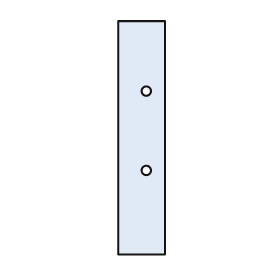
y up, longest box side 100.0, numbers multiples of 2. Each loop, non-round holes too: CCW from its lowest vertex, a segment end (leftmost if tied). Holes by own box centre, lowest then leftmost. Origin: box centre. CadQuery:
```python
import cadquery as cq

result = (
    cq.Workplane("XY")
    .moveTo(-10.0, -50.0)
    .lineTo(10.0, -50.0)
    .lineTo(10.0, 50.0)
    .lineTo(-10.0, 50.0)
    .close()
    .moveTo(2.0, -14.0)
    .circle(2.0)
    .moveTo(2.0, 20.0)
    .circle(2.0)
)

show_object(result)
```